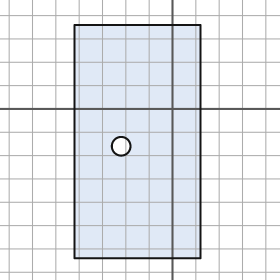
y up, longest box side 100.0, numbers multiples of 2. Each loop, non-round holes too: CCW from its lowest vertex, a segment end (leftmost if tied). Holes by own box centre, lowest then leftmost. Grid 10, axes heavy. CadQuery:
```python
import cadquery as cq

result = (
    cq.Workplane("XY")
    .moveTo(-42.0, -64.0)
    .lineTo(12.0, -64.0)
    .lineTo(12.0, 36.0)
    .lineTo(-42.0, 36.0)
    .close()
    .moveTo(-22.0, -16.0)
    .circle(4.0)
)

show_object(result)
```